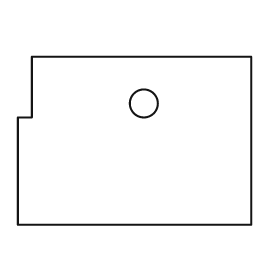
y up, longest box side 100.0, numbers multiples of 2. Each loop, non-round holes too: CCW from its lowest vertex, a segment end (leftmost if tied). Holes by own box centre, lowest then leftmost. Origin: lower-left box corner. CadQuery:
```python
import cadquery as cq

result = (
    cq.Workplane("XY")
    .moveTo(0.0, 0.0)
    .lineTo(100.0, 0.0)
    .lineTo(100.0, 72.0)
    .lineTo(6.0, 72.0)
    .lineTo(6.0, 46.0)
    .lineTo(0.0, 46.0)
    .close()
    .moveTo(54.0, 52.0)
    .circle(6.0)
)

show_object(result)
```